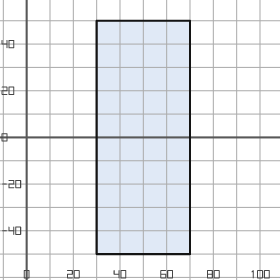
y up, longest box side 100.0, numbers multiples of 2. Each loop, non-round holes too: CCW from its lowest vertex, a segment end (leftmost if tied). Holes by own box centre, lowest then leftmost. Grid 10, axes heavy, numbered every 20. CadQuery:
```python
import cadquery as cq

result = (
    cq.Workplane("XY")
    .moveTo(30.0, -50.0)
    .lineTo(70.0, -50.0)
    .lineTo(70.0, 50.0)
    .lineTo(30.0, 50.0)
    .close()
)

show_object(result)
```